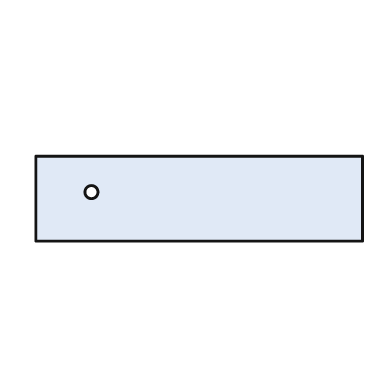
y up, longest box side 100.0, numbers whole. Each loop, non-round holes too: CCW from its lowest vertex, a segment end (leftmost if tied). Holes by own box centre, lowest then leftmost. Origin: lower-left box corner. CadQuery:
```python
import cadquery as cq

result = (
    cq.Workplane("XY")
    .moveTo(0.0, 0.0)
    .lineTo(100.0, 0.0)
    .lineTo(100.0, 26.0)
    .lineTo(0.0, 26.0)
    .close()
    .moveTo(17.0, 15.0)
    .circle(2.0)
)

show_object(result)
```